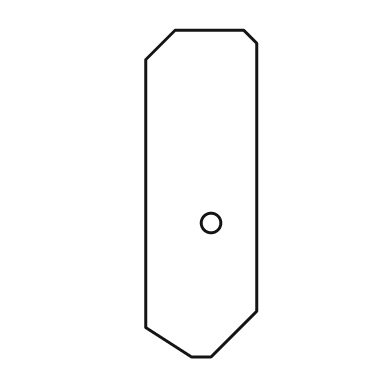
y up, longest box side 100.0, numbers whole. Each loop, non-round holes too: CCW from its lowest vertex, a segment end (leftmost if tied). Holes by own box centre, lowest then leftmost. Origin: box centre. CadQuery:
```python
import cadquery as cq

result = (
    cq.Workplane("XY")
    .moveTo(-3.0, -50.0)
    .lineTo(3.0, -50.0)
    .lineTo(17.0, -36.0)
    .lineTo(17.0, 46.0)
    .lineTo(13.0, 50.0)
    .lineTo(-8.0, 50.0)
    .lineTo(-17.0, 41.0)
    .lineTo(-17.0, -41.0)
    .close()
    .moveTo(3.0, -9.0)
    .circle(3.0)
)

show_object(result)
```